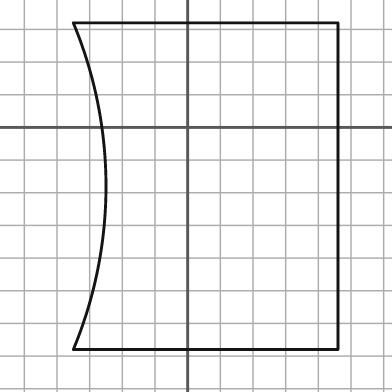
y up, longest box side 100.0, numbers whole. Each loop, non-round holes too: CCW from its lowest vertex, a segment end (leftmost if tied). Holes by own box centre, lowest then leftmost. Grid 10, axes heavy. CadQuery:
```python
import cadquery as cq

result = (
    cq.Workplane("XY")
    .moveTo(-35.0, -68.0)
    .lineTo(46.0, -68.0)
    .lineTo(46.0, 32.0)
    .lineTo(-35.0, 32.0)
    .threePointArc((-25.0, -18.0), (-35.0, -68.0))
    .close()
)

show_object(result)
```